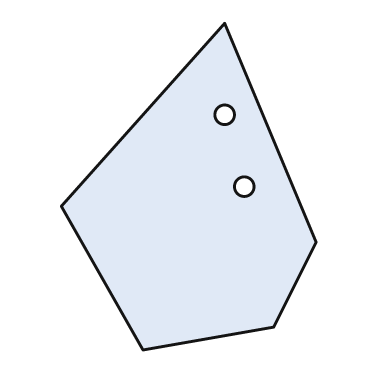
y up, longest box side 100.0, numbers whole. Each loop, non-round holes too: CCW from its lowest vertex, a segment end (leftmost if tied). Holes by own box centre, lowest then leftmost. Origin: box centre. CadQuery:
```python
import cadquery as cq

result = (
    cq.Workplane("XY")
    .moveTo(-14.0, -50.0)
    .lineTo(26.0, -43.0)
    .lineTo(39.0, -17.0)
    .lineTo(11.0, 50.0)
    .lineTo(-39.0, -6.0)
    .close()
    .moveTo(17.0, 0.0)
    .circle(3.0)
    .moveTo(11.0, 22.0)
    .circle(3.0)
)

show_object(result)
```